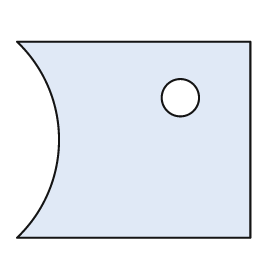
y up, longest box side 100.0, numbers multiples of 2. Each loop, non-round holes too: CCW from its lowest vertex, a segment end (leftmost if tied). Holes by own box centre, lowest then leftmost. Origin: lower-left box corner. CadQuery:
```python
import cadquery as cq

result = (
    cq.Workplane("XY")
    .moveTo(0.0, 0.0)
    .lineTo(100.0, 0.0)
    .lineTo(100.0, 84.0)
    .lineTo(0.0, 84.0)
    .threePointArc((18.0, 42.0), (0.0, 0.0))
    .close()
    .moveTo(70.0, 60.0)
    .circle(8.0)
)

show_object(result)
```